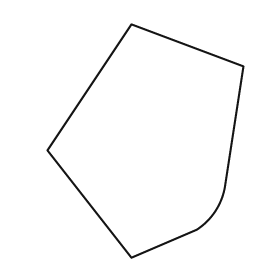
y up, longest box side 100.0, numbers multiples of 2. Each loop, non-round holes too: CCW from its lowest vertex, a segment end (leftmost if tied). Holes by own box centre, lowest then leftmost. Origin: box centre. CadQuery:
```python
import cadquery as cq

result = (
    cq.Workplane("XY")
    .moveTo(-6.0, -50.0)
    .lineTo(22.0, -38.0)
    .threePointArc((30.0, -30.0), (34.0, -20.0))
    .lineTo(42.0, 32.0)
    .lineTo(-6.0, 50.0)
    .lineTo(-42.0, -4.0)
    .close()
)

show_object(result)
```